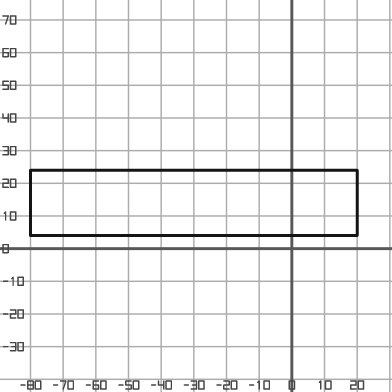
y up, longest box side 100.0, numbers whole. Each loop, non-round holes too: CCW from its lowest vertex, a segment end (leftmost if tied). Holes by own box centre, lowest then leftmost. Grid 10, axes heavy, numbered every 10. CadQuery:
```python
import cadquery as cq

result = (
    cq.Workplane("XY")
    .moveTo(-80.0, 4.0)
    .lineTo(20.0, 4.0)
    .lineTo(20.0, 24.0)
    .lineTo(-80.0, 24.0)
    .close()
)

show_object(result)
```